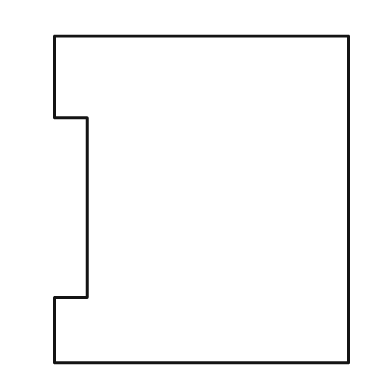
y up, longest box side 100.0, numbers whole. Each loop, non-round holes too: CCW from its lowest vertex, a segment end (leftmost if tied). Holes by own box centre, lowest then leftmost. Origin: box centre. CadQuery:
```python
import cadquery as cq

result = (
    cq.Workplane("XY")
    .moveTo(-45.0, -50.0)
    .lineTo(45.0, -50.0)
    .lineTo(45.0, 50.0)
    .lineTo(-45.0, 50.0)
    .lineTo(-45.0, 25.0)
    .lineTo(-35.0, 25.0)
    .lineTo(-35.0, -30.0)
    .lineTo(-45.0, -30.0)
    .close()
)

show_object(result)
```